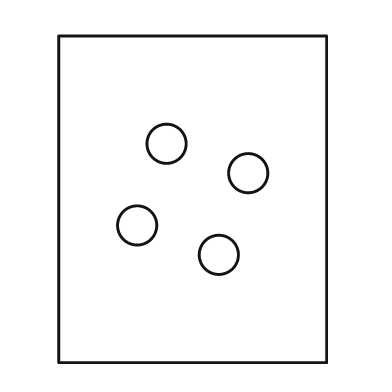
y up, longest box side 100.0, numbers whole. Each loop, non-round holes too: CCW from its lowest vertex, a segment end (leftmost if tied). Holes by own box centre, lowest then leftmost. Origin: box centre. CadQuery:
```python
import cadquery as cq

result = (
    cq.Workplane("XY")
    .moveTo(-41.0, -50.0)
    .lineTo(41.0, -50.0)
    .lineTo(41.0, 50.0)
    .lineTo(-41.0, 50.0)
    .close()
    .moveTo(8.0, -17.0)
    .circle(6.0)
    .moveTo(-17.0, -8.0)
    .circle(6.0)
    .moveTo(17.0, 8.0)
    .circle(6.0)
    .moveTo(-8.0, 17.0)
    .circle(6.0)
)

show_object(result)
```